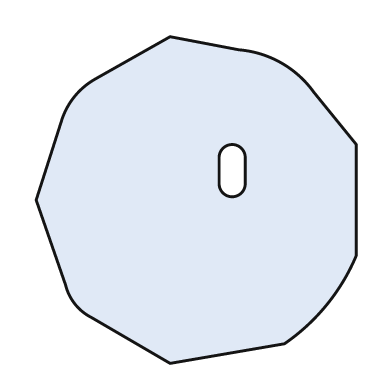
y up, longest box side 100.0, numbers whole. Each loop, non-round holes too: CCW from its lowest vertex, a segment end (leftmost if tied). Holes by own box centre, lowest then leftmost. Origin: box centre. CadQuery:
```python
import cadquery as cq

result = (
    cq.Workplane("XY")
    .moveTo(-8.0, -50.0)
    .lineTo(27.0, -44.0)
    .threePointArc((40.0, -32.0), (49.0, -17.0))
    .lineTo(49.0, 17.0)
    .lineTo(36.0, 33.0)
    .threePointArc((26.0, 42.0), (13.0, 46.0))
    .lineTo(-8.0, 50.0)
    .lineTo(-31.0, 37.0)
    .threePointArc((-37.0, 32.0), (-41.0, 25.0))
    .lineTo(-49.0, 0.0)
    .lineTo(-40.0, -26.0)
    .threePointArc((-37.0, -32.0), (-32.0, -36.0))
    .close()
    .moveTo(7.0, 5.0)
    .threePointArc((11.0, 1.0), (15.0, 5.0))
    .lineTo(15.0, 13.0)
    .threePointArc((11.0, 17.0), (7.0, 13.0))
    .close()
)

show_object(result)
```